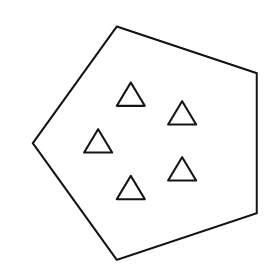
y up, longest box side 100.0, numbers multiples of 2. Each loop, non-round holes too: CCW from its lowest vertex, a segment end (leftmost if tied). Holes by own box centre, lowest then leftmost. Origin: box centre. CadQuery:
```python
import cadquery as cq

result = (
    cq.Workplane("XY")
    .moveTo(-12.0, -50.0)
    .lineTo(48.0, -30.0)
    .lineTo(48.0, 30.0)
    .lineTo(-12.0, 50.0)
    .lineTo(-48.0, 0.0)
    .close()
    .moveTo(-12.0, -24.0)
    .lineTo(0.0, -24.0)
    .lineTo(-6.0, -14.0)
    .close()
    .moveTo(10.0, -16.0)
    .lineTo(22.0, -16.0)
    .lineTo(16.0, -6.0)
    .close()
    .moveTo(-26.0, -4.0)
    .lineTo(-14.0, -4.0)
    .lineTo(-20.0, 6.0)
    .close()
    .moveTo(10.0, 8.0)
    .lineTo(22.0, 8.0)
    .lineTo(16.0, 18.0)
    .close()
    .moveTo(-12.0, 16.0)
    .lineTo(0.0, 16.0)
    .lineTo(-6.0, 26.0)
    .close()
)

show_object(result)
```